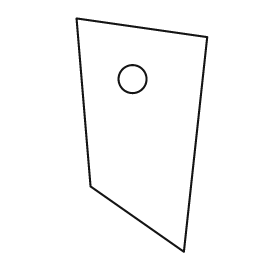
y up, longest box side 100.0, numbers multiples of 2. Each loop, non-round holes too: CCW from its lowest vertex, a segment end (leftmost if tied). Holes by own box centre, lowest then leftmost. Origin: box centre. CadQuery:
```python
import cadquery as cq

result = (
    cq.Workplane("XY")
    .moveTo(18.0, -50.0)
    .lineTo(28.0, 42.0)
    .lineTo(-28.0, 50.0)
    .lineTo(-22.0, -22.0)
    .close()
    .moveTo(-4.0, 24.0)
    .circle(6.0)
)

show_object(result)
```